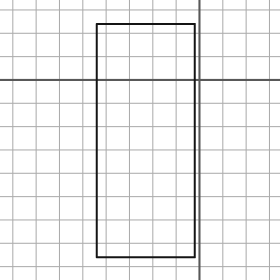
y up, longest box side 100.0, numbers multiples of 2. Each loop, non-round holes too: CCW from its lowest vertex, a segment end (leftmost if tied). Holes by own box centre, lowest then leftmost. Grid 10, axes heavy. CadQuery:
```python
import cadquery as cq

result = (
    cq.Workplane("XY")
    .moveTo(-44.0, -76.0)
    .lineTo(-2.0, -76.0)
    .lineTo(-2.0, 24.0)
    .lineTo(-44.0, 24.0)
    .close()
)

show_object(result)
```